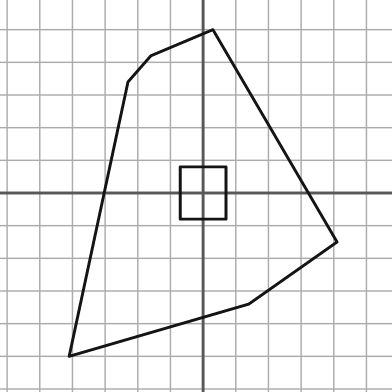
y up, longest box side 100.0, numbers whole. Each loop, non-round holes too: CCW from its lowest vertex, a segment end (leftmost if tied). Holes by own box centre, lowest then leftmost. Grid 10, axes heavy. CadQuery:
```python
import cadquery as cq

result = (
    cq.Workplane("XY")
    .moveTo(-41.0, -50.0)
    .lineTo(14.0, -34.0)
    .lineTo(41.0, -15.0)
    .lineTo(3.0, 50.0)
    .lineTo(-16.0, 42.0)
    .lineTo(-23.0, 34.0)
    .close()
    .moveTo(-7.0, -8.0)
    .lineTo(7.0, -8.0)
    .lineTo(7.0, 8.0)
    .lineTo(-7.0, 8.0)
    .close()
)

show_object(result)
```